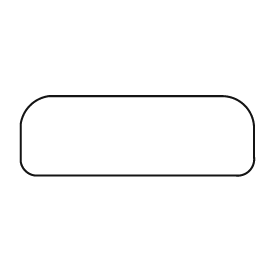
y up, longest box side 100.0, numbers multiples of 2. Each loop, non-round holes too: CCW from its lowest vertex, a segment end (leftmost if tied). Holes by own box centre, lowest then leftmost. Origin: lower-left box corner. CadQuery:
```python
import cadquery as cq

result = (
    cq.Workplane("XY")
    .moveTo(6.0, 0.0)
    .lineTo(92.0, 0.0)
    .threePointArc((98.0, 2.0), (100.0, 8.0))
    .lineTo(100.0, 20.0)
    .threePointArc((96.0, 30.0), (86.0, 34.0))
    .lineTo(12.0, 34.0)
    .threePointArc((4.0, 30.0), (0.0, 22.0))
    .lineTo(0.0, 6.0)
    .threePointArc((2.0, 2.0), (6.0, 0.0))
    .close()
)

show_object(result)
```